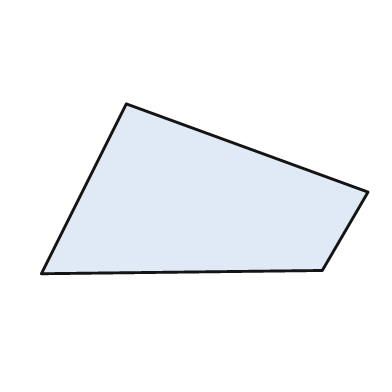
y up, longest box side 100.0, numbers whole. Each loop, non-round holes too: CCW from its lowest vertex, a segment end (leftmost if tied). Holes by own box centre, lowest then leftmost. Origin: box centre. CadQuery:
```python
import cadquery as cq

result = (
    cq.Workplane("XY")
    .moveTo(-50.0, -26.0)
    .lineTo(36.0, -25.0)
    .lineTo(50.0, -1.0)
    .lineTo(-24.0, 26.0)
    .close()
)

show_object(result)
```